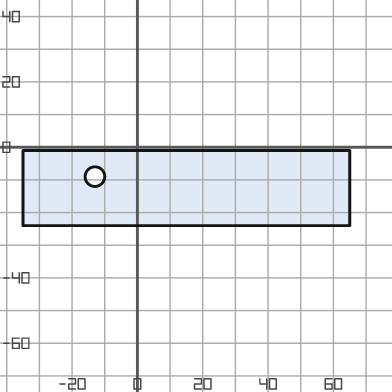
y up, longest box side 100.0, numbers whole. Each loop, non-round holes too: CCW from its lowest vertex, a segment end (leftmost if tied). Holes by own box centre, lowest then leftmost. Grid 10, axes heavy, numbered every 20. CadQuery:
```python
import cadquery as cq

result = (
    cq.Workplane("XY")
    .moveTo(-35.0, -24.0)
    .lineTo(65.0, -24.0)
    .lineTo(65.0, -1.0)
    .lineTo(-35.0, -1.0)
    .close()
    .moveTo(-13.0, -9.0)
    .circle(3.0)
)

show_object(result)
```